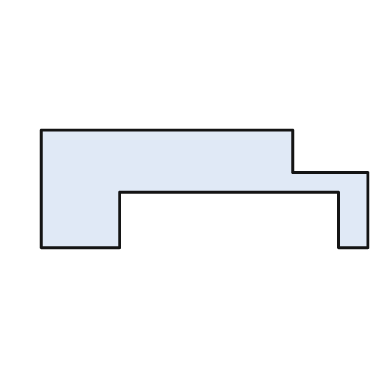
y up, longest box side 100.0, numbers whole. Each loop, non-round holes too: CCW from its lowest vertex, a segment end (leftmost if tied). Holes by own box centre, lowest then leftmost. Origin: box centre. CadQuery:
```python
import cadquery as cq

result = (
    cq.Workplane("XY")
    .moveTo(-50.0, -18.0)
    .lineTo(-26.0, -18.0)
    .lineTo(-26.0, -1.0)
    .lineTo(41.0, -1.0)
    .lineTo(41.0, -18.0)
    .lineTo(50.0, -18.0)
    .lineTo(50.0, 5.0)
    .lineTo(27.0, 5.0)
    .lineTo(27.0, 18.0)
    .lineTo(-50.0, 18.0)
    .close()
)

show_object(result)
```